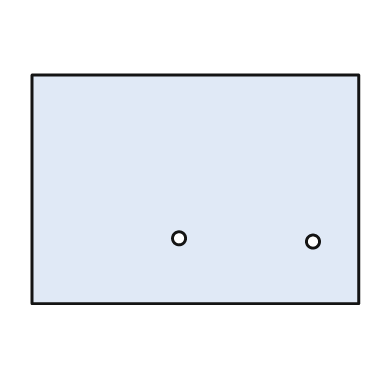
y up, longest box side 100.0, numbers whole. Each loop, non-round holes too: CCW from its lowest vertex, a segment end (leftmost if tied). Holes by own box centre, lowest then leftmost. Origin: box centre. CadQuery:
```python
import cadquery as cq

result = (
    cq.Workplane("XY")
    .moveTo(-50.0, -35.0)
    .lineTo(50.0, -35.0)
    .lineTo(50.0, 35.0)
    .lineTo(-50.0, 35.0)
    .close()
    .moveTo(36.0, -16.0)
    .circle(2.0)
    .moveTo(-5.0, -15.0)
    .circle(2.0)
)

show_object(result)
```